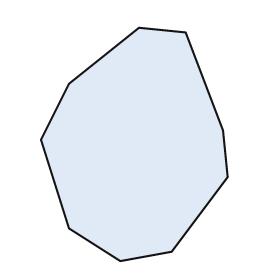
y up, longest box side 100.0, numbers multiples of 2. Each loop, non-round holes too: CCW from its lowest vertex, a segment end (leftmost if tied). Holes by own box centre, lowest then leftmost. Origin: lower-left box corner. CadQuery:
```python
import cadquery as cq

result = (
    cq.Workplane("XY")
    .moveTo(34.0, 0.0)
    .lineTo(56.0, 4.0)
    .lineTo(80.0, 36.0)
    .lineTo(78.0, 56.0)
    .lineTo(62.0, 98.0)
    .lineTo(42.0, 100.0)
    .lineTo(12.0, 76.0)
    .lineTo(0.0, 52.0)
    .lineTo(12.0, 14.0)
    .close()
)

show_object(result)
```